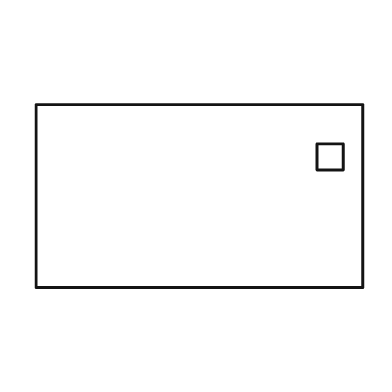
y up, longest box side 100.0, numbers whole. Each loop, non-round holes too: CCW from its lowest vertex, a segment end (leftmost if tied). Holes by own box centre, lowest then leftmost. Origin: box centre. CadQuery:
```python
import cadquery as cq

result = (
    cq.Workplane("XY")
    .moveTo(-50.0, -28.0)
    .lineTo(50.0, -28.0)
    .lineTo(50.0, 28.0)
    .lineTo(-50.0, 28.0)
    .close()
    .moveTo(36.0, 8.0)
    .lineTo(44.0, 8.0)
    .lineTo(44.0, 16.0)
    .lineTo(36.0, 16.0)
    .close()
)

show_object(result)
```